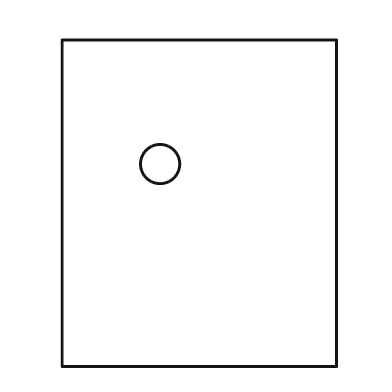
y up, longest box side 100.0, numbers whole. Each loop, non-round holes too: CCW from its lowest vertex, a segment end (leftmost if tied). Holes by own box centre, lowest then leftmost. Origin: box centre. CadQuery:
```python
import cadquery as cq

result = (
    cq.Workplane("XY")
    .moveTo(-42.0, -50.0)
    .lineTo(42.0, -50.0)
    .lineTo(42.0, 50.0)
    .lineTo(-42.0, 50.0)
    .close()
    .moveTo(-12.0, 12.0)
    .circle(6.0)
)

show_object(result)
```